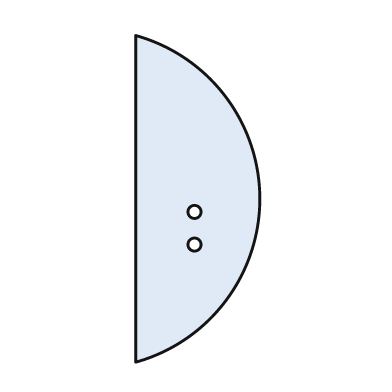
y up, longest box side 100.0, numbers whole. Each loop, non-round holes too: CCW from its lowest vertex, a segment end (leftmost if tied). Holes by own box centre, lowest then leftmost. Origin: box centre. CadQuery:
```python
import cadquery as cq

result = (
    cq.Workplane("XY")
    .moveTo(-19.0, -50.0)
    .threePointArc((19.0, 0.0), (-19.0, 50.0))
    .close()
    .moveTo(-1.0, -14.0)
    .circle(2.0)
    .moveTo(-1.0, -4.0)
    .circle(2.0)
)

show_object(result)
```